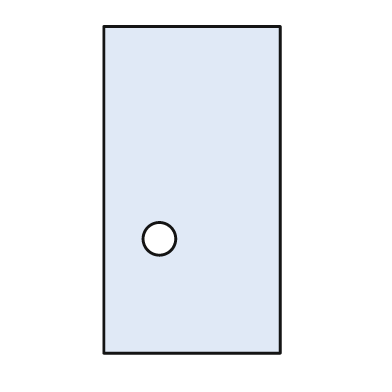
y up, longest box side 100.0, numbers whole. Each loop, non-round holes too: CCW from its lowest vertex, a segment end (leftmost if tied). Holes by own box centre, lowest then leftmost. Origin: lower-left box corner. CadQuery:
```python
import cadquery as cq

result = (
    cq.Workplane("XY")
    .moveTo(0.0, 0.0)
    .lineTo(54.0, 0.0)
    .lineTo(54.0, 100.0)
    .lineTo(0.0, 100.0)
    .close()
    .moveTo(17.0, 35.0)
    .circle(5.0)
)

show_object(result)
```